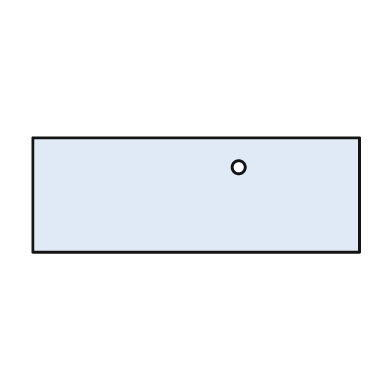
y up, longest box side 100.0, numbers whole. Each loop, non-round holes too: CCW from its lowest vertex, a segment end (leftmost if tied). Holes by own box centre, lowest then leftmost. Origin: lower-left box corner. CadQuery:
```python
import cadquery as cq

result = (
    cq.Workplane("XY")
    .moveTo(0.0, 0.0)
    .lineTo(100.0, 0.0)
    .lineTo(100.0, 35.0)
    .lineTo(0.0, 35.0)
    .close()
    .moveTo(63.0, 26.0)
    .circle(2.0)
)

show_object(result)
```